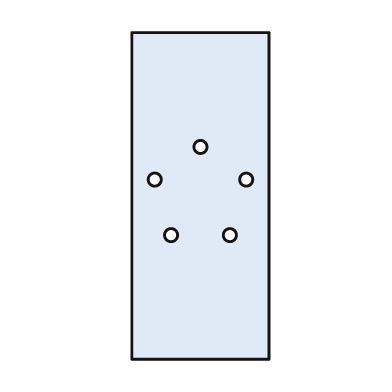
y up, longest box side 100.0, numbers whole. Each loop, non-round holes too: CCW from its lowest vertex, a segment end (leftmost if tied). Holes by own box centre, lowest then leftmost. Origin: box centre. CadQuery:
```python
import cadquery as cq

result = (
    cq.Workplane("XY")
    .moveTo(-21.0, -50.0)
    .lineTo(21.0, -50.0)
    .lineTo(21.0, 50.0)
    .lineTo(-21.0, 50.0)
    .close()
    .moveTo(-9.0, -12.0)
    .circle(2.0)
    .moveTo(9.0, -12.0)
    .circle(2.0)
    .moveTo(-14.0, 5.0)
    .circle(2.0)
    .moveTo(14.0, 5.0)
    .circle(2.0)
    .moveTo(0.0, 15.0)
    .circle(2.0)
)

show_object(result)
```